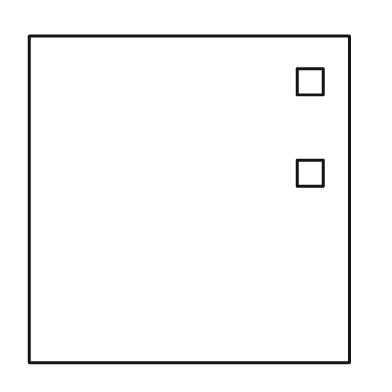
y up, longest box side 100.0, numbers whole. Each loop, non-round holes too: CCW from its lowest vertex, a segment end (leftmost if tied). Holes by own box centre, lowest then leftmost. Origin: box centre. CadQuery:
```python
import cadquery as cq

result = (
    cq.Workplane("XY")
    .moveTo(-49.0, -50.0)
    .lineTo(49.0, -50.0)
    .lineTo(49.0, 50.0)
    .lineTo(-49.0, 50.0)
    .close()
    .moveTo(33.0, 4.0)
    .lineTo(41.0, 4.0)
    .lineTo(41.0, 12.0)
    .lineTo(33.0, 12.0)
    .close()
    .moveTo(33.0, 32.0)
    .lineTo(41.0, 32.0)
    .lineTo(41.0, 40.0)
    .lineTo(33.0, 40.0)
    .close()
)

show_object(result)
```